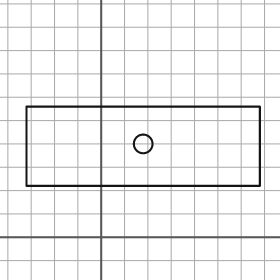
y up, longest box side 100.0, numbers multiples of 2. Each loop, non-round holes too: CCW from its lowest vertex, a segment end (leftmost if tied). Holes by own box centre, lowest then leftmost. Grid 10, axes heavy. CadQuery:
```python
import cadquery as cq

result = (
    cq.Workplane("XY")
    .moveTo(-32.0, 22.0)
    .lineTo(68.0, 22.0)
    .lineTo(68.0, 56.0)
    .lineTo(-32.0, 56.0)
    .close()
    .moveTo(18.0, 40.0)
    .circle(4.0)
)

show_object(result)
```